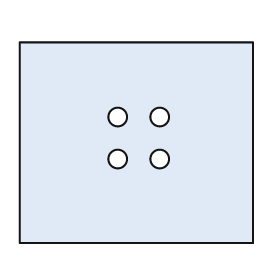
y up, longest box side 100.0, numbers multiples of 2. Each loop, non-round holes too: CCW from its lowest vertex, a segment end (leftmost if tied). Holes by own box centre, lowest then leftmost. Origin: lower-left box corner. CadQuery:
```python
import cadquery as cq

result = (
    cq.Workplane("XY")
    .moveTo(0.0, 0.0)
    .lineTo(100.0, 0.0)
    .lineTo(100.0, 86.0)
    .lineTo(0.0, 86.0)
    .close()
    .moveTo(42.0, 36.0)
    .circle(4.0)
    .moveTo(60.0, 36.0)
    .circle(4.0)
    .moveTo(42.0, 54.0)
    .circle(4.0)
    .moveTo(60.0, 54.0)
    .circle(4.0)
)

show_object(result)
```